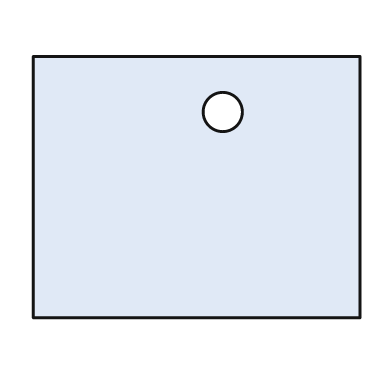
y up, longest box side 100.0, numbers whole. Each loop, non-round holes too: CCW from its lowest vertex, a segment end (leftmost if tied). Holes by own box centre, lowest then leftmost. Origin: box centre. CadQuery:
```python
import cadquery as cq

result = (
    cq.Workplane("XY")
    .moveTo(-50.0, -40.0)
    .lineTo(50.0, -40.0)
    .lineTo(50.0, 40.0)
    .lineTo(-50.0, 40.0)
    .close()
    .moveTo(8.0, 23.0)
    .circle(6.0)
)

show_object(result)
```